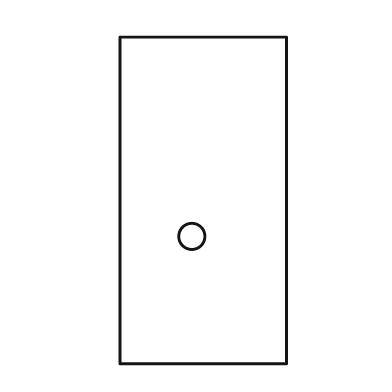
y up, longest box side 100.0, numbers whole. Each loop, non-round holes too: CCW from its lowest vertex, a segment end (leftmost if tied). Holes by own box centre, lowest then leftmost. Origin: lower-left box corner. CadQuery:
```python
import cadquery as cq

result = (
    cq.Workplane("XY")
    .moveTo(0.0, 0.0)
    .lineTo(51.0, 0.0)
    .lineTo(51.0, 100.0)
    .lineTo(0.0, 100.0)
    .close()
    .moveTo(22.0, 39.0)
    .circle(4.0)
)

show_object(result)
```